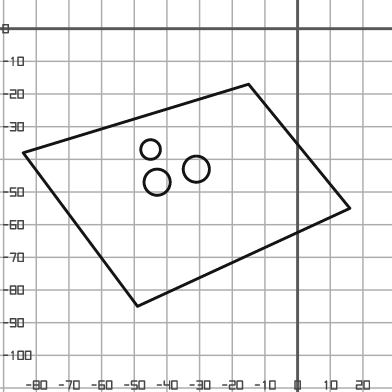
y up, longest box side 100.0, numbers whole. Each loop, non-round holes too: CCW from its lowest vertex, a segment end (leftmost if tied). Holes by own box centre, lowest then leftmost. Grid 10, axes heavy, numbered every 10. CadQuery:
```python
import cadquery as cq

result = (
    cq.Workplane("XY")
    .moveTo(-49.0, -85.0)
    .lineTo(16.0, -55.0)
    .lineTo(-15.0, -17.0)
    .lineTo(-84.0, -38.0)
    .close()
    .moveTo(-43.0, -47.0)
    .circle(4.0)
    .moveTo(-31.0, -43.0)
    .circle(4.0)
    .moveTo(-45.0, -37.0)
    .circle(3.0)
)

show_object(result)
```